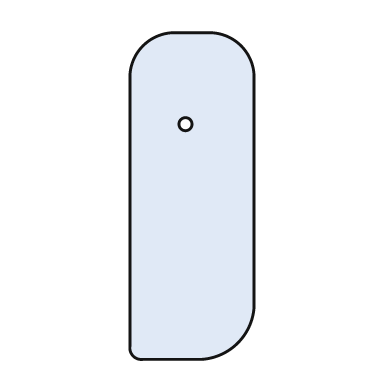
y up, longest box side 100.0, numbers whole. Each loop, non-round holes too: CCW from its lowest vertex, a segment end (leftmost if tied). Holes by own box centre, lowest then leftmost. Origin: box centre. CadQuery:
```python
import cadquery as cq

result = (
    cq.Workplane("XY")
    .moveTo(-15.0, -50.0)
    .lineTo(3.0, -50.0)
    .threePointArc((14.0, -45.0), (19.0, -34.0))
    .lineTo(19.0, 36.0)
    .threePointArc((15.0, 46.0), (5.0, 50.0))
    .lineTo(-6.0, 50.0)
    .threePointArc((-15.0, 46.0), (-19.0, 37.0))
    .lineTo(-19.0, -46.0)
    .threePointArc((-18.0, -49.0), (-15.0, -50.0))
    .close()
    .moveTo(-2.0, 22.0)
    .circle(2.0)
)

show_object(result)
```